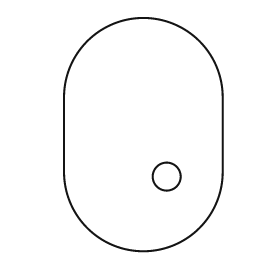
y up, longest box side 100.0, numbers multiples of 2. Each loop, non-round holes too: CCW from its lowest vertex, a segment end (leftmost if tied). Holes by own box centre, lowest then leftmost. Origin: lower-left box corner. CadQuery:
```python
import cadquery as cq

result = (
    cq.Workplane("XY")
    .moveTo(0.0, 34.0)
    .threePointArc((34.0, 0.0), (68.0, 34.0))
    .lineTo(68.0, 66.0)
    .threePointArc((34.0, 100.0), (0.0, 66.0))
    .close()
    .moveTo(44.0, 32.0)
    .circle(6.0)
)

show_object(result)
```